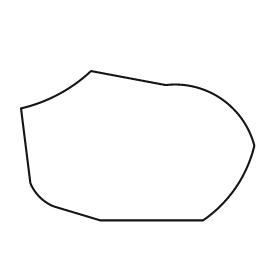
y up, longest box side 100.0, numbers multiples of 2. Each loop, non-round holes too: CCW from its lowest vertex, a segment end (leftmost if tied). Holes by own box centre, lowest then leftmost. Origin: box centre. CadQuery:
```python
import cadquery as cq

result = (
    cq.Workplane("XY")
    .moveTo(-16.0, -32.0)
    .lineTo(28.0, -32.0)
    .threePointArc((42.0, -18.0), (50.0, 0.0))
    .threePointArc((36.0, 20.0), (12.0, 26.0))
    .lineTo(-20.0, 32.0)
    .threePointArc((-34.0, 22.0), (-50.0, 16.0))
    .lineTo(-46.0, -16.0)
    .threePointArc((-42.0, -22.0), (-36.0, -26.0))
    .close()
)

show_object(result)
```